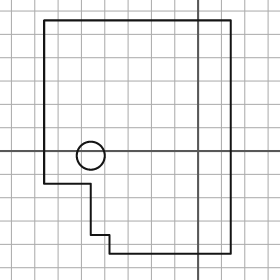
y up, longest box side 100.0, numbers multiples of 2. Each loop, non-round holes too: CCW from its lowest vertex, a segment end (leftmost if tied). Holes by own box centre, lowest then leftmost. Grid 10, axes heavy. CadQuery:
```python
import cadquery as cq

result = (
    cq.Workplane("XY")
    .moveTo(-38.0, -44.0)
    .lineTo(14.0, -44.0)
    .lineTo(14.0, 56.0)
    .lineTo(-66.0, 56.0)
    .lineTo(-66.0, -14.0)
    .lineTo(-46.0, -14.0)
    .lineTo(-46.0, -36.0)
    .lineTo(-38.0, -36.0)
    .close()
    .moveTo(-46.0, -2.0)
    .circle(6.0)
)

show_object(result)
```